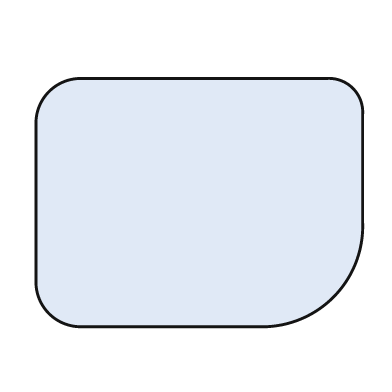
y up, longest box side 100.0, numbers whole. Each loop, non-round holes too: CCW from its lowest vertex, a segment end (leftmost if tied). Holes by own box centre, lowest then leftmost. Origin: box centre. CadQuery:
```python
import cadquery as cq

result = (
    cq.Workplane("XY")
    .moveTo(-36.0, -38.0)
    .lineTo(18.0, -38.0)
    .threePointArc((41.0, -29.0), (50.0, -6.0))
    .lineTo(50.0, 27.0)
    .threePointArc((47.0, 35.0), (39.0, 38.0))
    .lineTo(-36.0, 38.0)
    .threePointArc((-46.0, 34.0), (-50.0, 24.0))
    .lineTo(-50.0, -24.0)
    .threePointArc((-46.0, -34.0), (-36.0, -38.0))
    .close()
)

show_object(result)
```